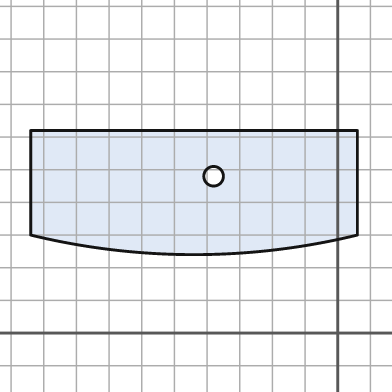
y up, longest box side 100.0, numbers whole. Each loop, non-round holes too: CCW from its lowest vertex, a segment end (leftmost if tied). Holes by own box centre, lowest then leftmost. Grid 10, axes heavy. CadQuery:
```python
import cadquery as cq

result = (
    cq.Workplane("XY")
    .moveTo(-94.0, 30.0)
    .threePointArc((-44.0, 24.0), (6.0, 30.0))
    .lineTo(6.0, 62.0)
    .lineTo(-94.0, 62.0)
    .close()
    .moveTo(-38.0, 48.0)
    .circle(3.0)
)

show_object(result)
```